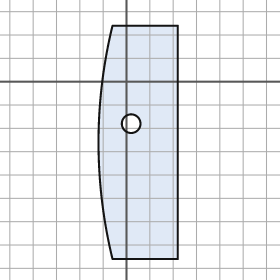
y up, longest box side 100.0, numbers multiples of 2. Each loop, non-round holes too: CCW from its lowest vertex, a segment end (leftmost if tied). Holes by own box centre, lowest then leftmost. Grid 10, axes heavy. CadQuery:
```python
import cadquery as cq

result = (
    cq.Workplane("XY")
    .moveTo(-6.0, -76.0)
    .lineTo(22.0, -76.0)
    .lineTo(22.0, 24.0)
    .lineTo(-6.0, 24.0)
    .threePointArc((-12.0, -26.0), (-6.0, -76.0))
    .close()
    .moveTo(2.0, -18.0)
    .circle(4.0)
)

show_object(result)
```